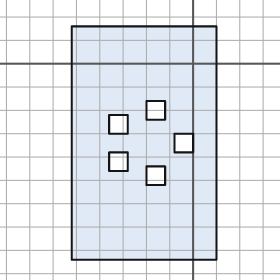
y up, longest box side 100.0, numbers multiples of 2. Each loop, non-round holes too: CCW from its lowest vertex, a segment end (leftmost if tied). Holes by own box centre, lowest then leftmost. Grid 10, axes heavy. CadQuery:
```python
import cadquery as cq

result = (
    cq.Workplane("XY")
    .moveTo(-52.0, -84.0)
    .lineTo(10.0, -84.0)
    .lineTo(10.0, 16.0)
    .lineTo(-52.0, 16.0)
    .close()
    .moveTo(-20.0, -52.0)
    .lineTo(-12.0, -52.0)
    .lineTo(-12.0, -44.0)
    .lineTo(-20.0, -44.0)
    .close()
    .moveTo(-36.0, -46.0)
    .lineTo(-28.0, -46.0)
    .lineTo(-28.0, -38.0)
    .lineTo(-36.0, -38.0)
    .close()
    .moveTo(-8.0, -38.0)
    .lineTo(0.0, -38.0)
    .lineTo(0.0, -30.0)
    .lineTo(-8.0, -30.0)
    .close()
    .moveTo(-36.0, -30.0)
    .lineTo(-28.0, -30.0)
    .lineTo(-28.0, -22.0)
    .lineTo(-36.0, -22.0)
    .close()
    .moveTo(-20.0, -24.0)
    .lineTo(-12.0, -24.0)
    .lineTo(-12.0, -16.0)
    .lineTo(-20.0, -16.0)
    .close()
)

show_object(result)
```